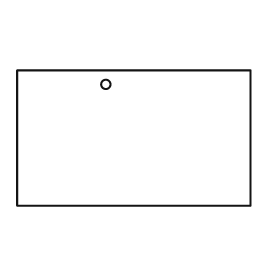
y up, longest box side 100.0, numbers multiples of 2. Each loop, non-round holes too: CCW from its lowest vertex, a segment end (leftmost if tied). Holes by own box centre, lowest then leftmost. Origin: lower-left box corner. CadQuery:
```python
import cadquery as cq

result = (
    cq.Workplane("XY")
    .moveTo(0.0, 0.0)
    .lineTo(100.0, 0.0)
    .lineTo(100.0, 58.0)
    .lineTo(0.0, 58.0)
    .close()
    .moveTo(38.0, 52.0)
    .circle(2.0)
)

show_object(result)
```